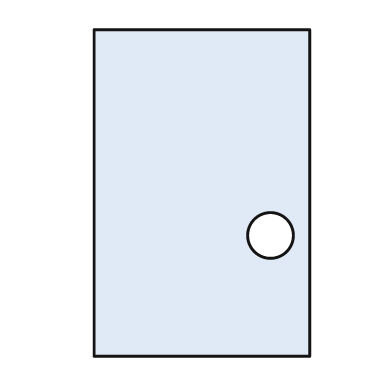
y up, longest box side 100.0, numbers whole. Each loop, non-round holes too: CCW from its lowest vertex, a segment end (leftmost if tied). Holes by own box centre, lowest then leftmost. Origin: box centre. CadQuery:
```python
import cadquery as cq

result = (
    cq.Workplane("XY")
    .moveTo(-33.0, -50.0)
    .lineTo(33.0, -50.0)
    .lineTo(33.0, 50.0)
    .lineTo(-33.0, 50.0)
    .close()
    .moveTo(21.0, -13.0)
    .circle(7.0)
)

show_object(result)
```